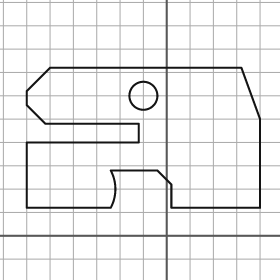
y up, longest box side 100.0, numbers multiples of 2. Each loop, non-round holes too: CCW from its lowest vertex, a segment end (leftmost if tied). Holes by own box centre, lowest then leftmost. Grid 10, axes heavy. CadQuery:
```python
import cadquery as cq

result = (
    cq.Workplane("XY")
    .moveTo(-60.0, 12.0)
    .lineTo(-24.0, 12.0)
    .threePointArc((-22.0, 20.0), (-24.0, 28.0))
    .lineTo(-4.0, 28.0)
    .lineTo(2.0, 22.0)
    .lineTo(2.0, 12.0)
    .lineTo(40.0, 12.0)
    .lineTo(40.0, 50.0)
    .lineTo(32.0, 72.0)
    .lineTo(-50.0, 72.0)
    .lineTo(-60.0, 62.0)
    .lineTo(-60.0, 56.0)
    .lineTo(-52.0, 48.0)
    .lineTo(-12.0, 48.0)
    .lineTo(-12.0, 40.0)
    .lineTo(-60.0, 40.0)
    .close()
    .moveTo(-10.0, 60.0)
    .circle(6.0)
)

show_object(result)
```